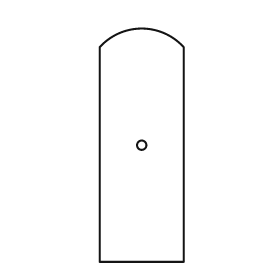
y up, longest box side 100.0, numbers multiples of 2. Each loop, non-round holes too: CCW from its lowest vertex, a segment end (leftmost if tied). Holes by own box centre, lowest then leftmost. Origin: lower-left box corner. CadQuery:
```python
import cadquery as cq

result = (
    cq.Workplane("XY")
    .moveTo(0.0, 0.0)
    .lineTo(36.0, 0.0)
    .lineTo(36.0, 92.0)
    .threePointArc((18.0, 100.0), (0.0, 92.0))
    .close()
    .moveTo(18.0, 50.0)
    .circle(2.0)
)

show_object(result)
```